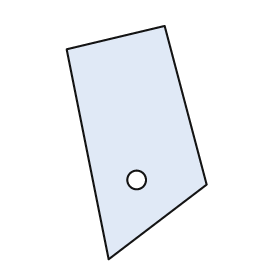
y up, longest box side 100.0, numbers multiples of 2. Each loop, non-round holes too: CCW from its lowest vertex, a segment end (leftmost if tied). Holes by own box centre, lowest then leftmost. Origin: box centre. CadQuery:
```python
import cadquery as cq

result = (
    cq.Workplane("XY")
    .moveTo(-12.0, -50.0)
    .lineTo(30.0, -18.0)
    .lineTo(12.0, 50.0)
    .lineTo(-30.0, 40.0)
    .close()
    .moveTo(0.0, -16.0)
    .circle(4.0)
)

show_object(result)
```